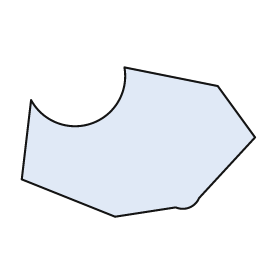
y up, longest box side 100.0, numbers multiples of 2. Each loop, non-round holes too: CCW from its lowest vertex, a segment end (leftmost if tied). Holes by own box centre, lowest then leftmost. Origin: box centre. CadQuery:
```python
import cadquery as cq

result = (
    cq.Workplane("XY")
    .moveTo(-10.0, -32.0)
    .lineTo(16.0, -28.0)
    .threePointArc((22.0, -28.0), (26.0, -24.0))
    .lineTo(50.0, 2.0)
    .lineTo(34.0, 24.0)
    .lineTo(-6.0, 32.0)
    .threePointArc((-20.0, 8.0), (-46.0, 18.0))
    .lineTo(-50.0, -16.0)
    .close()
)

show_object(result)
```